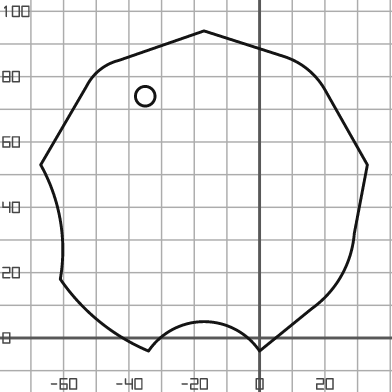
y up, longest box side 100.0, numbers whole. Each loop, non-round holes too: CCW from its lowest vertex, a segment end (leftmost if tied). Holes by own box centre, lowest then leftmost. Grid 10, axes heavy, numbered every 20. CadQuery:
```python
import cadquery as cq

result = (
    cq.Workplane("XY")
    .moveTo(-34.0, -4.0)
    .threePointArc((-17.0, 5.0), (0.0, -4.0))
    .lineTo(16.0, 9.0)
    .threePointArc((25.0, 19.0), (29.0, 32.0))
    .lineTo(33.0, 53.0)
    .lineTo(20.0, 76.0)
    .threePointArc((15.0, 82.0), (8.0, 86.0))
    .lineTo(-17.0, 94.0)
    .lineTo(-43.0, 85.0)
    .threePointArc((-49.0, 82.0), (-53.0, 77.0))
    .lineTo(-67.0, 53.0)
    .threePointArc((-61.0, 36.0), (-61.0, 18.0))
    .threePointArc((-49.0, 5.0), (-34.0, -4.0))
    .close()
    .moveTo(-35.0, 74.0)
    .circle(3.0)
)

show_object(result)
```